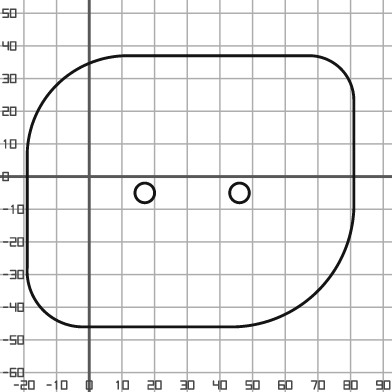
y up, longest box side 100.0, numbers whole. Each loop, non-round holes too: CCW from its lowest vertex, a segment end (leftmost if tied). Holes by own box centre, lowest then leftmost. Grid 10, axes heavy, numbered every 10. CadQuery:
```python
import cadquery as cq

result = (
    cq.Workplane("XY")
    .moveTo(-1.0, -46.0)
    .lineTo(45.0, -46.0)
    .threePointArc((70.0, -35.0), (81.0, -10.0))
    .lineTo(81.0, 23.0)
    .threePointArc((77.0, 33.0), (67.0, 37.0))
    .lineTo(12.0, 37.0)
    .threePointArc((-10.0, 28.0), (-19.0, 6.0))
    .lineTo(-19.0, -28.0)
    .threePointArc((-14.0, -41.0), (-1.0, -46.0))
    .close()
    .moveTo(17.0, -5.0)
    .circle(3.0)
    .moveTo(46.0, -5.0)
    .circle(3.0)
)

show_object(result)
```